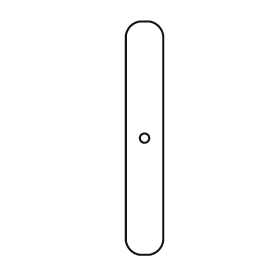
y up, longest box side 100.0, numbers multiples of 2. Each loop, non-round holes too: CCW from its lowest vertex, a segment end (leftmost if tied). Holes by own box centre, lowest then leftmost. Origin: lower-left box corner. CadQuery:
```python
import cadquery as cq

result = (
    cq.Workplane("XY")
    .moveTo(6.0, 0.0)
    .lineTo(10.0, 0.0)
    .threePointArc((14.0, 2.0), (16.0, 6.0))
    .lineTo(16.0, 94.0)
    .threePointArc((14.0, 98.0), (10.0, 100.0))
    .lineTo(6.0, 100.0)
    .threePointArc((2.0, 98.0), (0.0, 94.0))
    .lineTo(0.0, 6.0)
    .threePointArc((2.0, 2.0), (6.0, 0.0))
    .close()
    .moveTo(8.0, 50.0)
    .circle(2.0)
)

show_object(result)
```